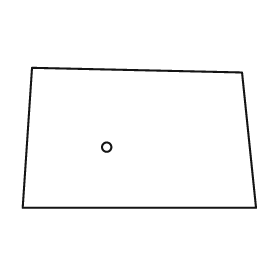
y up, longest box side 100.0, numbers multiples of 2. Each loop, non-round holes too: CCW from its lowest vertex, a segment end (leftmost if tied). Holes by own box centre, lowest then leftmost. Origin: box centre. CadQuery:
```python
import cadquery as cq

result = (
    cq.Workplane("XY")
    .moveTo(-50.0, -30.0)
    .lineTo(50.0, -30.0)
    .lineTo(44.0, 28.0)
    .lineTo(-46.0, 30.0)
    .close()
    .moveTo(-14.0, -4.0)
    .circle(2.0)
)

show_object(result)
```